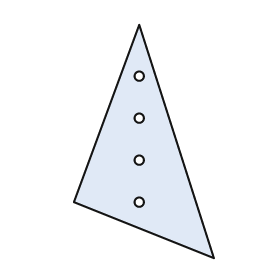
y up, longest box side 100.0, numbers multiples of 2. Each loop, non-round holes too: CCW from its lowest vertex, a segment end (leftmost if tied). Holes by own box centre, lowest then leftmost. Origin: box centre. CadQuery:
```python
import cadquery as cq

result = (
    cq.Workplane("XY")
    .moveTo(30.0, -50.0)
    .lineTo(-2.0, 50.0)
    .lineTo(-30.0, -26.0)
    .close()
    .moveTo(-2.0, -26.0)
    .circle(2.0)
    .moveTo(-2.0, -8.0)
    .circle(2.0)
    .moveTo(-2.0, 10.0)
    .circle(2.0)
    .moveTo(-2.0, 28.0)
    .circle(2.0)
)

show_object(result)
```